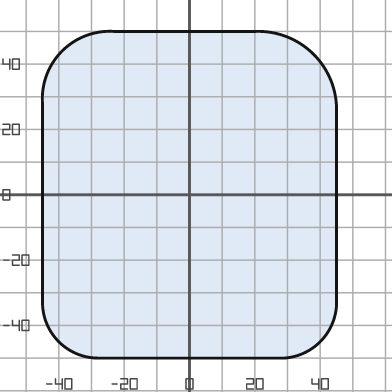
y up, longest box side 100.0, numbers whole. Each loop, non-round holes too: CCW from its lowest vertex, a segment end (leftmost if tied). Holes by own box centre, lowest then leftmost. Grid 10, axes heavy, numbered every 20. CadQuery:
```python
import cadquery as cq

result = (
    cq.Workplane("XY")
    .moveTo(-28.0, -50.0)
    .lineTo(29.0, -50.0)
    .threePointArc((40.0, -45.0), (45.0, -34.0))
    .lineTo(45.0, 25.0)
    .threePointArc((38.0, 43.0), (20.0, 50.0))
    .lineTo(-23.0, 50.0)
    .threePointArc((-39.0, 44.0), (-45.0, 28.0))
    .lineTo(-45.0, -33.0)
    .threePointArc((-40.0, -45.0), (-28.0, -50.0))
    .close()
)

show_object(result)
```